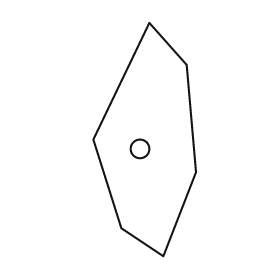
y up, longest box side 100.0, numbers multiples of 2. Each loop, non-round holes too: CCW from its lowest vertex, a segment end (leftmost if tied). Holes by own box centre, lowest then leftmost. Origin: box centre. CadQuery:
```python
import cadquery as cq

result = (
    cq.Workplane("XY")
    .moveTo(8.0, -50.0)
    .lineTo(22.0, -14.0)
    .lineTo(18.0, 32.0)
    .lineTo(2.0, 50.0)
    .lineTo(-22.0, 0.0)
    .lineTo(-10.0, -38.0)
    .close()
    .moveTo(-2.0, -4.0)
    .circle(4.0)
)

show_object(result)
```